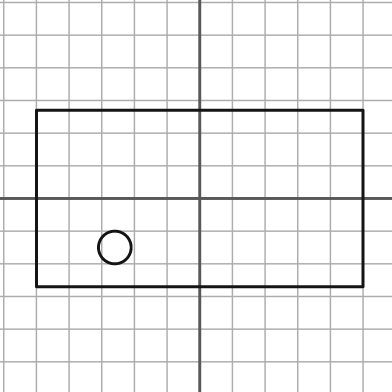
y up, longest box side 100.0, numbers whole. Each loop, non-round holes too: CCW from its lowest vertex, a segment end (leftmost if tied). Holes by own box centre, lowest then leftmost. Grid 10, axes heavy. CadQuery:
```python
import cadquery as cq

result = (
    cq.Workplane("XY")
    .moveTo(-50.0, -27.0)
    .lineTo(50.0, -27.0)
    .lineTo(50.0, 27.0)
    .lineTo(-50.0, 27.0)
    .close()
    .moveTo(-26.0, -15.0)
    .circle(5.0)
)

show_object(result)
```